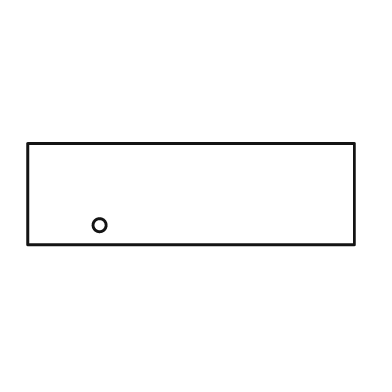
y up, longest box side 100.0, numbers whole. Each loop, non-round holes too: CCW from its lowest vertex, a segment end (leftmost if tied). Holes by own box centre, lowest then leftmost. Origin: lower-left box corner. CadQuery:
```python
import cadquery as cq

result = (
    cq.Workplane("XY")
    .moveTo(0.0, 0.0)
    .lineTo(100.0, 0.0)
    .lineTo(100.0, 31.0)
    .lineTo(0.0, 31.0)
    .close()
    .moveTo(22.0, 6.0)
    .circle(2.0)
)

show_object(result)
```